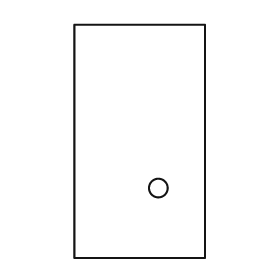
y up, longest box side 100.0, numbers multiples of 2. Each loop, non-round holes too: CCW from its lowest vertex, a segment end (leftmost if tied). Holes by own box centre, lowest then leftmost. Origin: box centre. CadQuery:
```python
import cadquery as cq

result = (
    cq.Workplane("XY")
    .moveTo(-28.0, -50.0)
    .lineTo(28.0, -50.0)
    .lineTo(28.0, 50.0)
    .lineTo(-28.0, 50.0)
    .close()
    .moveTo(8.0, -20.0)
    .circle(4.0)
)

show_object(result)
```